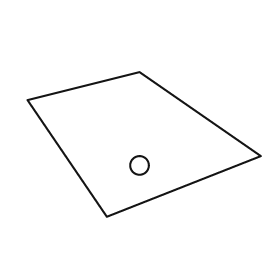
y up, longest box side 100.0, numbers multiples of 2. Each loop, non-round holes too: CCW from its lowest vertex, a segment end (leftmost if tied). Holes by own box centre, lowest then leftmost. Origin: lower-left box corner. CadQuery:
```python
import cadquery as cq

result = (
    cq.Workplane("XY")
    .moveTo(34.0, 0.0)
    .lineTo(100.0, 26.0)
    .lineTo(48.0, 62.0)
    .lineTo(0.0, 50.0)
    .close()
    .moveTo(48.0, 22.0)
    .circle(4.0)
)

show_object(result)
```